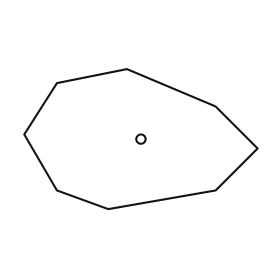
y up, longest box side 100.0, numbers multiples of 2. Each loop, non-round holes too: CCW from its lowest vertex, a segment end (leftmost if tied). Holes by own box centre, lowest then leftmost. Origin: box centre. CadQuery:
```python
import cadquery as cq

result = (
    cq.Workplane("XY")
    .moveTo(-14.0, -30.0)
    .lineTo(32.0, -22.0)
    .lineTo(50.0, -4.0)
    .lineTo(32.0, 14.0)
    .lineTo(-6.0, 30.0)
    .lineTo(-36.0, 24.0)
    .lineTo(-50.0, 2.0)
    .lineTo(-36.0, -22.0)
    .close()
    .moveTo(0.0, 0.0)
    .circle(2.0)
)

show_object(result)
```